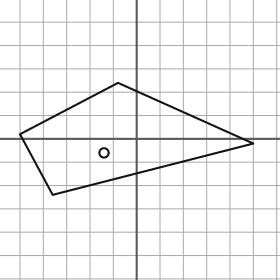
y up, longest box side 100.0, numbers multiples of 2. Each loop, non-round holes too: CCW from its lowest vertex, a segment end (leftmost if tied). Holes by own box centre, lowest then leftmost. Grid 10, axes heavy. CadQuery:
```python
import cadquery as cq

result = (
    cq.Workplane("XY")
    .moveTo(-36.0, -24.0)
    .lineTo(50.0, -2.0)
    .lineTo(-8.0, 24.0)
    .lineTo(-50.0, 2.0)
    .close()
    .moveTo(-14.0, -6.0)
    .circle(2.0)
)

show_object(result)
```